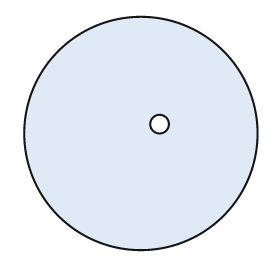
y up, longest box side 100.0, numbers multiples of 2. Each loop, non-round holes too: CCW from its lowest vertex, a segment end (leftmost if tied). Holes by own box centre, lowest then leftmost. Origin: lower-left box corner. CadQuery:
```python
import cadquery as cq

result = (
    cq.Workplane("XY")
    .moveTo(50.0, 50.0)
    .circle(50.0)
    .moveTo(58.0, 54.0)
    .circle(4.0)
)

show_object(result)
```